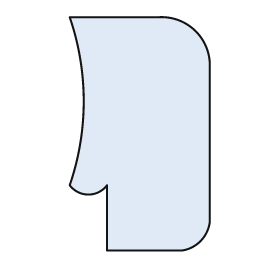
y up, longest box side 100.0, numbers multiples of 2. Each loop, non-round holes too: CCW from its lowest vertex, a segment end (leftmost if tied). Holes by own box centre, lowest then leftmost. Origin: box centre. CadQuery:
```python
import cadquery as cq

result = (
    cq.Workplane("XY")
    .moveTo(-14.0, -50.0)
    .lineTo(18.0, -50.0)
    .threePointArc((26.0, -46.0), (30.0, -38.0))
    .lineTo(30.0, 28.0)
    .threePointArc((24.0, 44.0), (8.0, 50.0))
    .lineTo(-30.0, 50.0)
    .threePointArc((-24.0, 14.0), (-30.0, -22.0))
    .threePointArc((-22.0, -26.0), (-14.0, -22.0))
    .close()
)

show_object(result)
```